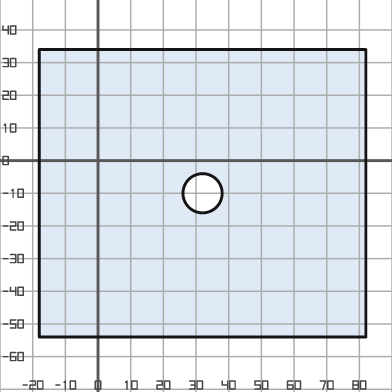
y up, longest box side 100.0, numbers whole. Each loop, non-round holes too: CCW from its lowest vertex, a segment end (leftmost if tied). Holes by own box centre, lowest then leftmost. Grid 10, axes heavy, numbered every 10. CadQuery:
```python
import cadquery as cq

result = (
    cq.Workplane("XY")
    .moveTo(-18.0, -54.0)
    .lineTo(82.0, -54.0)
    .lineTo(82.0, 34.0)
    .lineTo(-18.0, 34.0)
    .close()
    .moveTo(32.0, -10.0)
    .circle(6.0)
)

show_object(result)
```